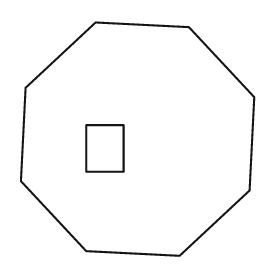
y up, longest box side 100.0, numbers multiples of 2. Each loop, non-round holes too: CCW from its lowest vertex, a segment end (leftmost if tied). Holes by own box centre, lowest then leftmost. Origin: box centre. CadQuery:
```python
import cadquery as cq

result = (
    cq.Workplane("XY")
    .moveTo(18.0, -50.0)
    .lineTo(48.0, -22.0)
    .lineTo(50.0, 18.0)
    .lineTo(22.0, 48.0)
    .lineTo(-18.0, 50.0)
    .lineTo(-48.0, 22.0)
    .lineTo(-50.0, -18.0)
    .lineTo(-22.0, -48.0)
    .close()
    .moveTo(-22.0, -14.0)
    .lineTo(-6.0, -14.0)
    .lineTo(-6.0, 6.0)
    .lineTo(-22.0, 6.0)
    .close()
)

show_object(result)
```